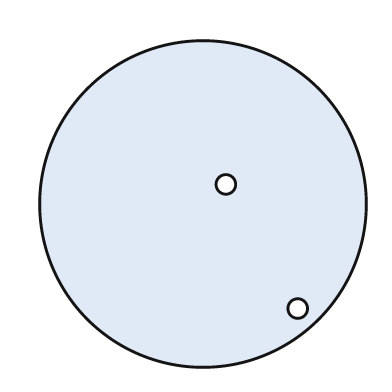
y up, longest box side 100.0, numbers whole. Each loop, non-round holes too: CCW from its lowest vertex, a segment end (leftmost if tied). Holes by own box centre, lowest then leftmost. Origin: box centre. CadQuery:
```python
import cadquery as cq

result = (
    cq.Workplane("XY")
    .moveTo(0.0, 0.0)
    .circle(50.0)
    .moveTo(29.0, -32.0)
    .circle(3.0)
    .moveTo(7.0, 6.0)
    .circle(3.0)
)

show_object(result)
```